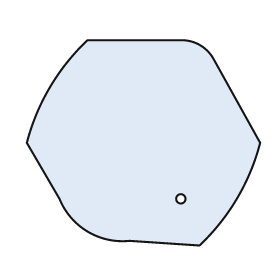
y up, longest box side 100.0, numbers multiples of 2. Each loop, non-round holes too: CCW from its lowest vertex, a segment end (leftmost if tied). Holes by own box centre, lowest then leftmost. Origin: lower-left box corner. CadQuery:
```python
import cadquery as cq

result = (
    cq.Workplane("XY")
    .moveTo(74.0, 0.0)
    .threePointArc((90.0, 20.0), (100.0, 44.0))
    .lineTo(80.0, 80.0)
    .threePointArc((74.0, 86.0), (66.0, 88.0))
    .lineTo(26.0, 88.0)
    .threePointArc((10.0, 68.0), (0.0, 44.0))
    .lineTo(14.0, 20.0)
    .threePointArc((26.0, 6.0), (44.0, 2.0))
    .close()
    .moveTo(66.0, 20.0)
    .circle(2.0)
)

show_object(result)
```